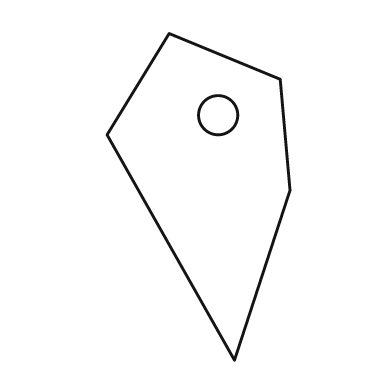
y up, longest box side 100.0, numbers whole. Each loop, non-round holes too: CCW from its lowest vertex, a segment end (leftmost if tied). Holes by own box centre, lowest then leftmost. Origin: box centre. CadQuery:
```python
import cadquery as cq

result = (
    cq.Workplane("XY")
    .moveTo(11.0, -50.0)
    .lineTo(28.0, 2.0)
    .lineTo(25.0, 36.0)
    .lineTo(-9.0, 50.0)
    .lineTo(-28.0, 19.0)
    .close()
    .moveTo(6.0, 25.0)
    .circle(6.0)
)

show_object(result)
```